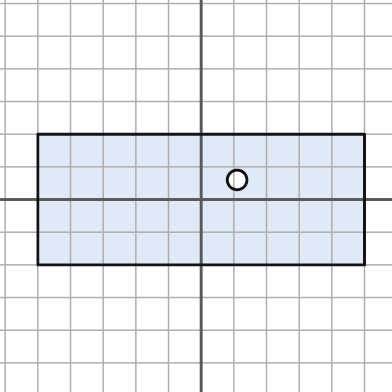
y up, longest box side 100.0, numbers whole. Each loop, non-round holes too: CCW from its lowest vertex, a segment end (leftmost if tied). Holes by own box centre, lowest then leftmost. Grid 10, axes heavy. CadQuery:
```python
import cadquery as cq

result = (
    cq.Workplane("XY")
    .moveTo(-50.0, -20.0)
    .lineTo(50.0, -20.0)
    .lineTo(50.0, 20.0)
    .lineTo(-50.0, 20.0)
    .close()
    .moveTo(11.0, 6.0)
    .circle(3.0)
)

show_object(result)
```